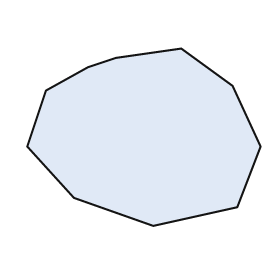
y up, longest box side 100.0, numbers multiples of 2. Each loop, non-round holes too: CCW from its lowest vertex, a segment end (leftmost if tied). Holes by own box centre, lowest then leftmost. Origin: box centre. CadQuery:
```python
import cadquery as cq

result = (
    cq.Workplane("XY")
    .moveTo(4.0, -38.0)
    .lineTo(40.0, -30.0)
    .lineTo(50.0, -4.0)
    .lineTo(38.0, 22.0)
    .lineTo(16.0, 38.0)
    .lineTo(-12.0, 34.0)
    .lineTo(-24.0, 30.0)
    .lineTo(-42.0, 20.0)
    .lineTo(-50.0, -4.0)
    .lineTo(-30.0, -26.0)
    .close()
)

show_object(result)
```